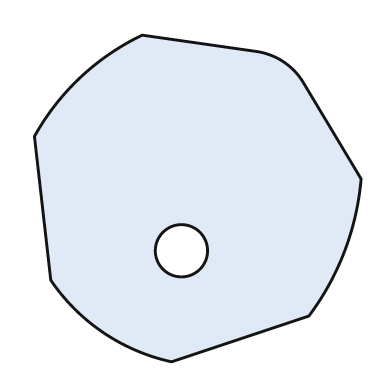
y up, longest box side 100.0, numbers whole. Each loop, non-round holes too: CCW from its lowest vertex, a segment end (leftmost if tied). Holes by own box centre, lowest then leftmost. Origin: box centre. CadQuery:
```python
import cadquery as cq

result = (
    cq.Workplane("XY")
    .moveTo(-8.0, -50.0)
    .lineTo(34.0, -36.0)
    .threePointArc((45.0, -16.0), (50.0, 6.0))
    .lineTo(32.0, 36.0)
    .threePointArc((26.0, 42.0), (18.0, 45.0))
    .lineTo(-17.0, 50.0)
    .threePointArc((-36.0, 37.0), (-50.0, 19.0))
    .lineTo(-45.0, -25.0)
    .threePointArc((-29.0, -41.0), (-8.0, -50.0))
    .close()
    .moveTo(-5.0, -16.0)
    .circle(8.0)
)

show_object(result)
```